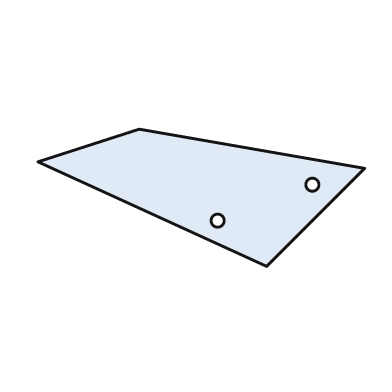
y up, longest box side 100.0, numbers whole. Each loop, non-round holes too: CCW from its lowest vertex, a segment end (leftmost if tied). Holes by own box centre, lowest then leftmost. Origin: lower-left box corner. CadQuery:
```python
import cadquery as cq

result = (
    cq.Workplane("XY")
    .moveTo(70.0, 0.0)
    .lineTo(100.0, 30.0)
    .lineTo(31.0, 42.0)
    .lineTo(0.0, 32.0)
    .close()
    .moveTo(55.0, 14.0)
    .circle(2.0)
    .moveTo(84.0, 25.0)
    .circle(2.0)
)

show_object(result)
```